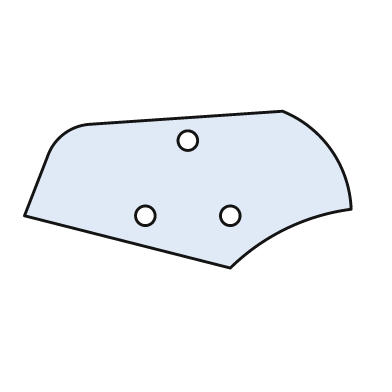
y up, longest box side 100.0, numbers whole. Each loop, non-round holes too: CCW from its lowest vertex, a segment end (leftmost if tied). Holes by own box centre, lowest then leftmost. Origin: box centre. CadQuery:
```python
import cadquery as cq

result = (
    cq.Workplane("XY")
    .moveTo(13.0, -24.0)
    .threePointArc((30.0, -12.0), (50.0, -6.0))
    .threePointArc((44.0, 12.0), (29.0, 24.0))
    .lineTo(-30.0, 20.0)
    .threePointArc((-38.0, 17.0), (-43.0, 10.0))
    .lineTo(-50.0, -8.0)
    .close()
    .moveTo(-13.0, -8.0)
    .circle(3.0)
    .moveTo(13.0, -8.0)
    .circle(3.0)
    .moveTo(0.0, 15.0)
    .circle(3.0)
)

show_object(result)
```